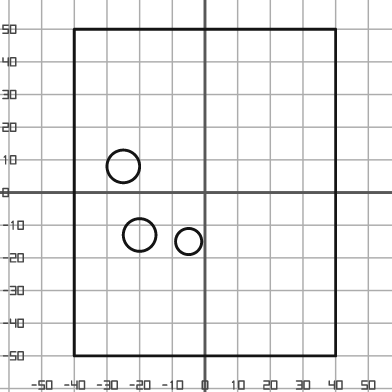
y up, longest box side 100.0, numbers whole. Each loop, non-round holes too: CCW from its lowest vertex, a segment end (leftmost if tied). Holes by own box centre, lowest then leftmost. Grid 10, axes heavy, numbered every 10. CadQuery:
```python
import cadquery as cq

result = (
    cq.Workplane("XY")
    .moveTo(-40.0, -50.0)
    .lineTo(40.0, -50.0)
    .lineTo(40.0, 50.0)
    .lineTo(-40.0, 50.0)
    .close()
    .moveTo(-5.0, -15.0)
    .circle(4.0)
    .moveTo(-20.0, -13.0)
    .circle(5.0)
    .moveTo(-25.0, 8.0)
    .circle(5.0)
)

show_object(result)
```